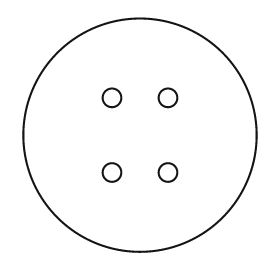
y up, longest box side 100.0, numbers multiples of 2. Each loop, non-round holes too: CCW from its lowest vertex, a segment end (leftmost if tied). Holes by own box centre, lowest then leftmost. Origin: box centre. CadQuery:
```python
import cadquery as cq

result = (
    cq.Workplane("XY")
    .moveTo(0.0, 0.0)
    .circle(50.0)
    .moveTo(-12.0, -16.0)
    .circle(4.0)
    .moveTo(12.0, -16.0)
    .circle(4.0)
    .moveTo(-12.0, 16.0)
    .circle(4.0)
    .moveTo(12.0, 16.0)
    .circle(4.0)
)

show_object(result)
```